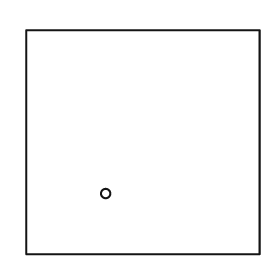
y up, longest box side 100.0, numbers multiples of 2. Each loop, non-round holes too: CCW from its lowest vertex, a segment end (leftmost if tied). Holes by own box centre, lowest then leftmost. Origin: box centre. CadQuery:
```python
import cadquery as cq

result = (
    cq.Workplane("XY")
    .moveTo(-50.0, -48.0)
    .lineTo(50.0, -48.0)
    .lineTo(50.0, 48.0)
    .lineTo(-50.0, 48.0)
    .close()
    .moveTo(-16.0, -22.0)
    .circle(2.0)
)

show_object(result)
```